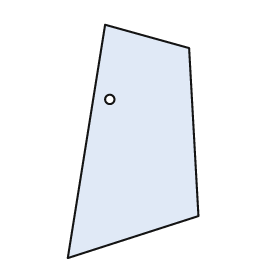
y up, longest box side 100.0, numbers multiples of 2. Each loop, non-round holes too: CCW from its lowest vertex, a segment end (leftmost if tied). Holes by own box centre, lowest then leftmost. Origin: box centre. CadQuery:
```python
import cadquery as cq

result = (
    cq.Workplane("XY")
    .moveTo(-28.0, -50.0)
    .lineTo(28.0, -32.0)
    .lineTo(24.0, 40.0)
    .lineTo(-12.0, 50.0)
    .close()
    .moveTo(-10.0, 18.0)
    .circle(2.0)
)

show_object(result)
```